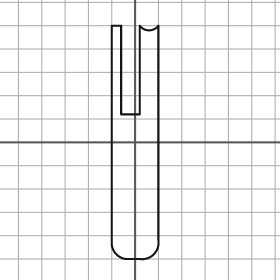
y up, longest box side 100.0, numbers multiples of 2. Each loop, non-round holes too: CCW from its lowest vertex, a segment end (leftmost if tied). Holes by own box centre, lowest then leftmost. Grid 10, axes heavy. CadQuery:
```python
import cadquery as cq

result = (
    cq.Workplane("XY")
    .moveTo(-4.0, -50.0)
    .lineTo(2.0, -50.0)
    .threePointArc((8.0, -48.0), (10.0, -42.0))
    .lineTo(10.0, 50.0)
    .threePointArc((6.0, 48.0), (2.0, 50.0))
    .lineTo(2.0, 12.0)
    .lineTo(-6.0, 12.0)
    .lineTo(-6.0, 50.0)
    .lineTo(-10.0, 50.0)
    .lineTo(-10.0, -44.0)
    .threePointArc((-8.0, -48.0), (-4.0, -50.0))
    .close()
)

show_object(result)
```